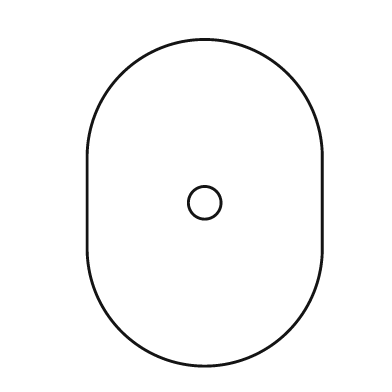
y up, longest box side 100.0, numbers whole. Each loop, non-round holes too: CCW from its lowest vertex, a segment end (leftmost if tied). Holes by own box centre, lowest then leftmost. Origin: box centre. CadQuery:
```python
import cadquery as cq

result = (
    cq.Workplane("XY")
    .moveTo(-36.0, -14.0)
    .threePointArc((0.0, -50.0), (36.0, -14.0))
    .lineTo(36.0, 14.0)
    .threePointArc((0.0, 50.0), (-36.0, 14.0))
    .close()
    .moveTo(0.0, 0.0)
    .circle(5.0)
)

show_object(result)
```